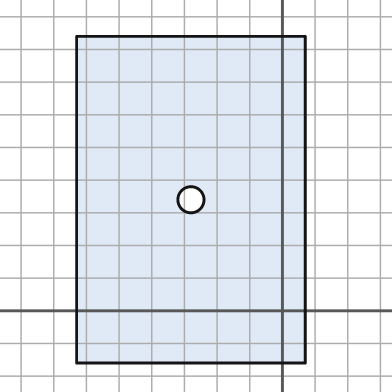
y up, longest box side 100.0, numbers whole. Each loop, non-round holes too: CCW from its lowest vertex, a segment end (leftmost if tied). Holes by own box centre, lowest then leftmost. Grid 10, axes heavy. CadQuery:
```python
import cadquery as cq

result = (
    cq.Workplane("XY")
    .moveTo(-63.0, -16.0)
    .lineTo(7.0, -16.0)
    .lineTo(7.0, 84.0)
    .lineTo(-63.0, 84.0)
    .close()
    .moveTo(-28.0, 34.0)
    .circle(4.0)
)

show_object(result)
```